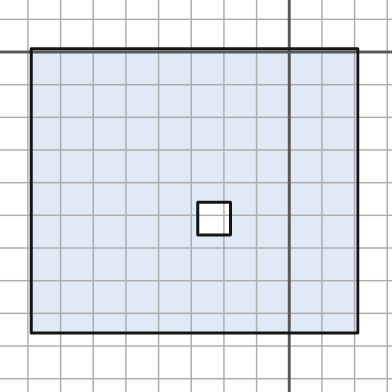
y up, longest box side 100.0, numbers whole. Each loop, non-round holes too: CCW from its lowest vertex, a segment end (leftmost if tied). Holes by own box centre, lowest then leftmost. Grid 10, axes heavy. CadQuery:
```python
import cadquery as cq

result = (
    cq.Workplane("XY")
    .moveTo(-79.0, -86.0)
    .lineTo(21.0, -86.0)
    .lineTo(21.0, 1.0)
    .lineTo(-79.0, 1.0)
    .close()
    .moveTo(-28.0, -56.0)
    .lineTo(-18.0, -56.0)
    .lineTo(-18.0, -46.0)
    .lineTo(-28.0, -46.0)
    .close()
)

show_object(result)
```